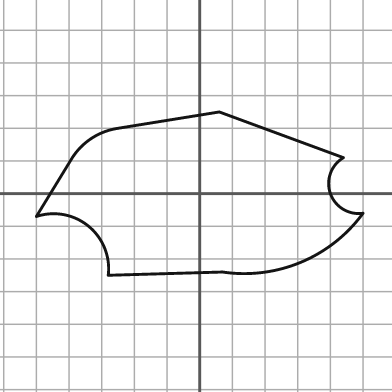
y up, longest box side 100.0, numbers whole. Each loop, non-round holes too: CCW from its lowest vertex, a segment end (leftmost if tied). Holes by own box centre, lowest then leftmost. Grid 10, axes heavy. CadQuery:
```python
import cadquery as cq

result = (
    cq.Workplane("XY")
    .moveTo(-28.0, -25.0)
    .lineTo(7.0, -24.0)
    .threePointArc((31.0, -21.0), (50.0, -6.0))
    .threePointArc((40.0, 0.0), (44.0, 11.0))
    .lineTo(6.0, 25.0)
    .lineTo(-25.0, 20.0)
    .threePointArc((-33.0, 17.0), (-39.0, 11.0))
    .lineTo(-50.0, -7.0)
    .threePointArc((-34.0, -10.0), (-28.0, -25.0))
    .close()
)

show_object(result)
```